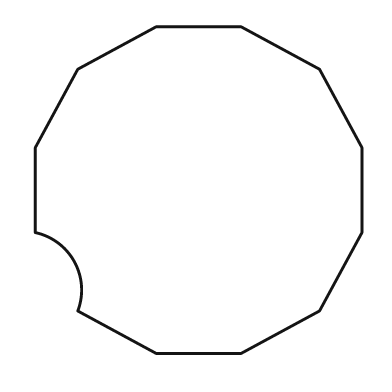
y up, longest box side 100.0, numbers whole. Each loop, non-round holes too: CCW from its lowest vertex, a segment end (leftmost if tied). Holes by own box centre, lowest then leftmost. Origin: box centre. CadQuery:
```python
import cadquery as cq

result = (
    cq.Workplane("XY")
    .moveTo(-13.0, -50.0)
    .lineTo(13.0, -50.0)
    .lineTo(37.0, -37.0)
    .lineTo(50.0, -13.0)
    .lineTo(50.0, 13.0)
    .lineTo(37.0, 37.0)
    .lineTo(13.0, 50.0)
    .lineTo(-13.0, 50.0)
    .lineTo(-37.0, 37.0)
    .lineTo(-50.0, 13.0)
    .lineTo(-50.0, -13.0)
    .threePointArc((-38.0, -22.0), (-37.0, -37.0))
    .close()
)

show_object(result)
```